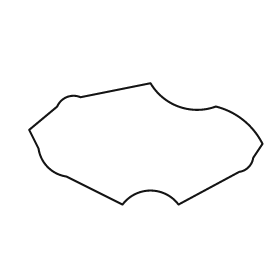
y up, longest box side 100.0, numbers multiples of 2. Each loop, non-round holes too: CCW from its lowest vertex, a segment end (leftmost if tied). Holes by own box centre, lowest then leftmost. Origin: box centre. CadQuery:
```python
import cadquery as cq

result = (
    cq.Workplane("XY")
    .moveTo(-10.0, -26.0)
    .threePointArc((2.0, -20.0), (14.0, -26.0))
    .lineTo(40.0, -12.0)
    .threePointArc((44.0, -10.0), (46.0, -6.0))
    .lineTo(50.0, 0.0)
    .threePointArc((42.0, 10.0), (30.0, 16.0))
    .threePointArc((14.0, 16.0), (2.0, 26.0))
    .lineTo(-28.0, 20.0)
    .threePointArc((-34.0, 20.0), (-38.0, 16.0))
    .lineTo(-50.0, 6.0)
    .lineTo(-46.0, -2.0)
    .threePointArc((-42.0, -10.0), (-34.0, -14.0))
    .close()
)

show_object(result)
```